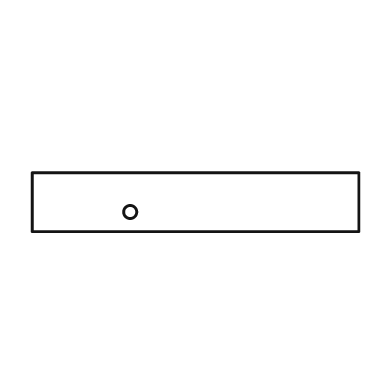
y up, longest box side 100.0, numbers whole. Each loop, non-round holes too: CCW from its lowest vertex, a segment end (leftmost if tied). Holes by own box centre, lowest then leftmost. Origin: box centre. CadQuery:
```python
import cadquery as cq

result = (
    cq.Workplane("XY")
    .moveTo(-50.0, -9.0)
    .lineTo(50.0, -9.0)
    .lineTo(50.0, 9.0)
    .lineTo(-50.0, 9.0)
    .close()
    .moveTo(-20.0, -3.0)
    .circle(2.0)
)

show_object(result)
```